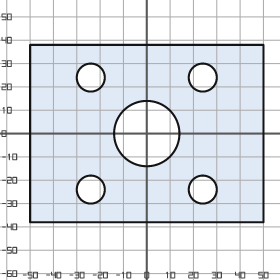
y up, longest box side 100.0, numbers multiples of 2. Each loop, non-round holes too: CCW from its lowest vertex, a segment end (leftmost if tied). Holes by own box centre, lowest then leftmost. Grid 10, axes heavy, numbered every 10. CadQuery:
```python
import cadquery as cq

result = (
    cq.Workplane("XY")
    .moveTo(-50.0, -38.0)
    .lineTo(50.0, -38.0)
    .lineTo(50.0, 38.0)
    .lineTo(-50.0, 38.0)
    .close()
    .moveTo(-24.0, -24.0)
    .circle(6.0)
    .moveTo(24.0, -24.0)
    .circle(6.0)
    .moveTo(0.0, 0.0)
    .circle(14.0)
    .moveTo(-24.0, 24.0)
    .circle(6.0)
    .moveTo(24.0, 24.0)
    .circle(6.0)
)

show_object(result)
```